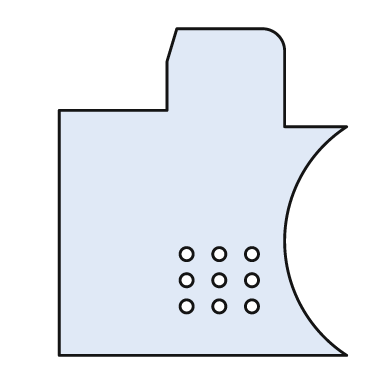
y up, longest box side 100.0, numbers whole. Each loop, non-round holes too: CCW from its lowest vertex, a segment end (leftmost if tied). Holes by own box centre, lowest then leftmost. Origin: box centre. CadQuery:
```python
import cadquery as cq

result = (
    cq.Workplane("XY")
    .moveTo(-44.0, -50.0)
    .lineTo(44.0, -50.0)
    .threePointArc((25.0, -15.0), (44.0, 20.0))
    .lineTo(25.0, 20.0)
    .lineTo(25.0, 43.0)
    .threePointArc((23.0, 48.0), (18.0, 50.0))
    .lineTo(-8.0, 50.0)
    .lineTo(-11.0, 40.0)
    .lineTo(-11.0, 25.0)
    .lineTo(-44.0, 25.0)
    .close()
    .moveTo(-5.0, -35.0)
    .circle(2.0)
    .moveTo(5.0, -35.0)
    .circle(2.0)
    .moveTo(15.0, -35.0)
    .circle(2.0)
    .moveTo(-5.0, -27.0)
    .circle(2.0)
    .moveTo(5.0, -27.0)
    .circle(2.0)
    .moveTo(15.0, -27.0)
    .circle(2.0)
    .moveTo(-5.0, -19.0)
    .circle(2.0)
    .moveTo(5.0, -19.0)
    .circle(2.0)
    .moveTo(15.0, -19.0)
    .circle(2.0)
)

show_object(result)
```